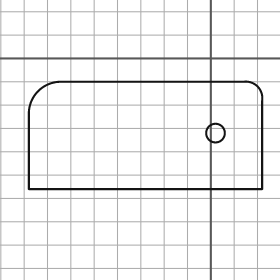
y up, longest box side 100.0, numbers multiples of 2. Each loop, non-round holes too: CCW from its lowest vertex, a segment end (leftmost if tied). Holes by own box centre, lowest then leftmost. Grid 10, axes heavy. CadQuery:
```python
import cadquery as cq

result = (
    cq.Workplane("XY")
    .moveTo(-78.0, -56.0)
    .lineTo(22.0, -56.0)
    .lineTo(22.0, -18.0)
    .threePointArc((20.0, -12.0), (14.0, -10.0))
    .lineTo(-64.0, -10.0)
    .threePointArc((-74.0, -14.0), (-78.0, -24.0))
    .close()
    .moveTo(2.0, -32.0)
    .circle(4.0)
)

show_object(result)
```